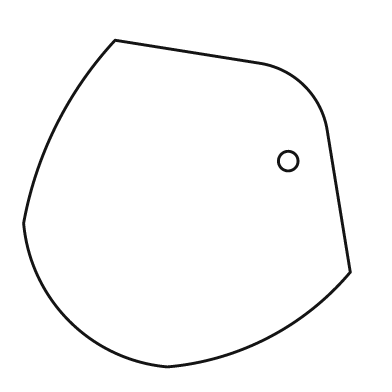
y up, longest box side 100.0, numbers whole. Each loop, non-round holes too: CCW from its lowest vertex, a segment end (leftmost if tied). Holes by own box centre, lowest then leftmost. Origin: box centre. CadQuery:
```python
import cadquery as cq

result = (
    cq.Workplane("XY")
    .moveTo(-6.0, -50.0)
    .threePointArc((25.0, -41.0), (50.0, -21.0))
    .lineTo(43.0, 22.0)
    .threePointArc((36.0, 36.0), (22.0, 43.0))
    .lineTo(-22.0, 50.0)
    .threePointArc((-40.0, 24.0), (-50.0, -6.0))
    .threePointArc((-36.0, -36.0), (-6.0, -50.0))
    .close()
    .moveTo(31.0, 13.0)
    .circle(3.0)
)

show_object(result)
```